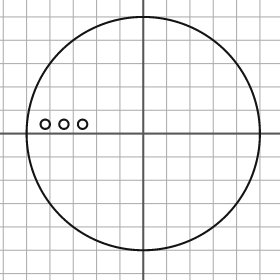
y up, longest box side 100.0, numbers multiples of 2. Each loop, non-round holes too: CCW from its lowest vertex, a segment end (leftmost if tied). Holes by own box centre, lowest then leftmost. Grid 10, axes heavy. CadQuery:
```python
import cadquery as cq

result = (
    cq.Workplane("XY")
    .moveTo(0.0, 0.0)
    .circle(50.0)
    .moveTo(-42.0, 4.0)
    .circle(2.0)
    .moveTo(-34.0, 4.0)
    .circle(2.0)
    .moveTo(-26.0, 4.0)
    .circle(2.0)
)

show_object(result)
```